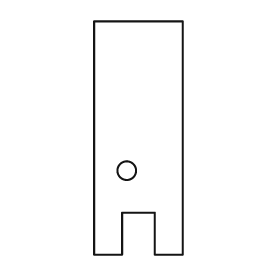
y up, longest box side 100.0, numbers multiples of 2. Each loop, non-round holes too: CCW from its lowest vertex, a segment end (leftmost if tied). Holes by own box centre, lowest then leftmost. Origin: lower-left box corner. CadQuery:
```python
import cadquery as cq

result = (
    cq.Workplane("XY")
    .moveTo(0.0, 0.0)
    .lineTo(12.0, 0.0)
    .lineTo(12.0, 18.0)
    .lineTo(26.0, 18.0)
    .lineTo(26.0, 0.0)
    .lineTo(38.0, 0.0)
    .lineTo(38.0, 100.0)
    .lineTo(0.0, 100.0)
    .close()
    .moveTo(14.0, 36.0)
    .circle(4.0)
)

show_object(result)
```